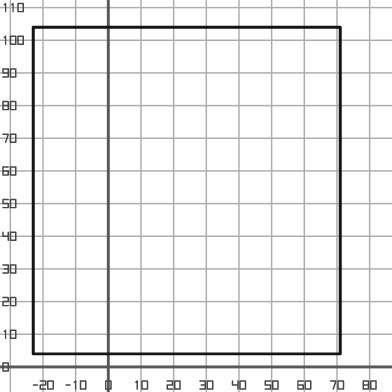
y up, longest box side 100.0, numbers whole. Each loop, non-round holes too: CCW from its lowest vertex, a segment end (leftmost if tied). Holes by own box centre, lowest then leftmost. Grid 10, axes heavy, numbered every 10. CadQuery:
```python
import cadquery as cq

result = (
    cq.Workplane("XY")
    .moveTo(-23.0, 4.0)
    .lineTo(71.0, 4.0)
    .lineTo(71.0, 104.0)
    .lineTo(-23.0, 104.0)
    .close()
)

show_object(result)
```